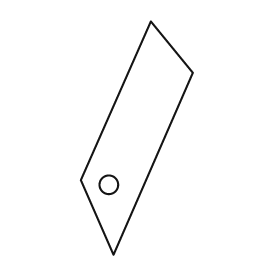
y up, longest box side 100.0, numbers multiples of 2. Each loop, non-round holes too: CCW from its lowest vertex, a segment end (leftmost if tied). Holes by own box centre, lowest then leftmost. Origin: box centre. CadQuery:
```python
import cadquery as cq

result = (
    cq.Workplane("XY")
    .moveTo(-10.0, -50.0)
    .lineTo(24.0, 28.0)
    .lineTo(6.0, 50.0)
    .lineTo(-24.0, -18.0)
    .close()
    .moveTo(-12.0, -20.0)
    .circle(4.0)
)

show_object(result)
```